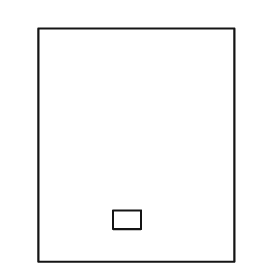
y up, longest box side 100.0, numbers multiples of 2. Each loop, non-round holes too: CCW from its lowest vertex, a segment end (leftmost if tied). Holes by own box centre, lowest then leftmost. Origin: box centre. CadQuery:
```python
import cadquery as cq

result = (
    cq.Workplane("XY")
    .moveTo(-42.0, -50.0)
    .lineTo(42.0, -50.0)
    .lineTo(42.0, 50.0)
    .lineTo(-42.0, 50.0)
    .close()
    .moveTo(-10.0, -36.0)
    .lineTo(2.0, -36.0)
    .lineTo(2.0, -28.0)
    .lineTo(-10.0, -28.0)
    .close()
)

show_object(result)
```